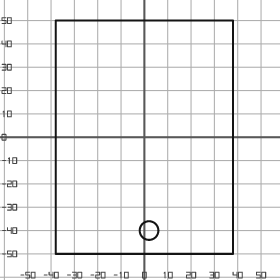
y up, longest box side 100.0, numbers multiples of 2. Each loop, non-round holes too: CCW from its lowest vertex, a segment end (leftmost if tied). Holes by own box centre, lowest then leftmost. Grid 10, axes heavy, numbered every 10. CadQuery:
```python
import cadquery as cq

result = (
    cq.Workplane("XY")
    .moveTo(-38.0, -50.0)
    .lineTo(38.0, -50.0)
    .lineTo(38.0, 50.0)
    .lineTo(-38.0, 50.0)
    .close()
    .moveTo(2.0, -40.0)
    .circle(4.0)
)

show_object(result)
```